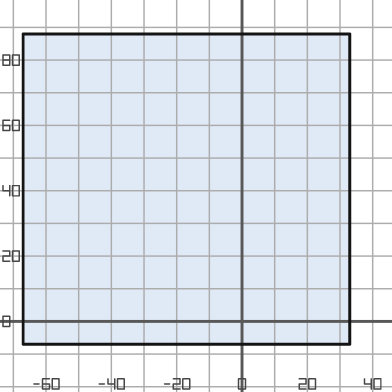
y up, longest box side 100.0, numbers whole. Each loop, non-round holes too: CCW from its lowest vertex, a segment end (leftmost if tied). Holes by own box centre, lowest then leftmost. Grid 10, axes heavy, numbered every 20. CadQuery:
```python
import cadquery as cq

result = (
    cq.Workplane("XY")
    .moveTo(-67.0, -7.0)
    .lineTo(33.0, -7.0)
    .lineTo(33.0, 88.0)
    .lineTo(-67.0, 88.0)
    .close()
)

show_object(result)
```